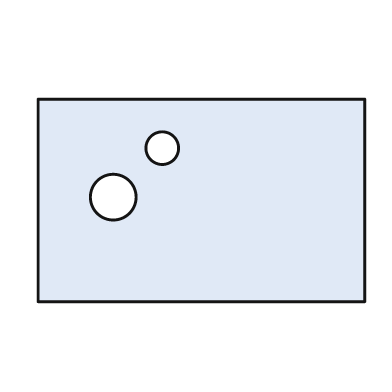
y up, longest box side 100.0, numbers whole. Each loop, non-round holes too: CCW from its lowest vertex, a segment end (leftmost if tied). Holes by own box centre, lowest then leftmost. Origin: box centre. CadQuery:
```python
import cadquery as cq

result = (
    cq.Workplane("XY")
    .moveTo(-50.0, -31.0)
    .lineTo(50.0, -31.0)
    .lineTo(50.0, 31.0)
    .lineTo(-50.0, 31.0)
    .close()
    .moveTo(-27.0, 1.0)
    .circle(7.0)
    .moveTo(-12.0, 16.0)
    .circle(5.0)
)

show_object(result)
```